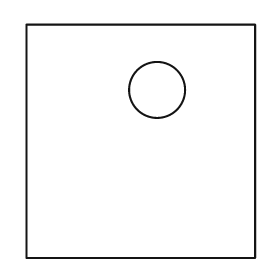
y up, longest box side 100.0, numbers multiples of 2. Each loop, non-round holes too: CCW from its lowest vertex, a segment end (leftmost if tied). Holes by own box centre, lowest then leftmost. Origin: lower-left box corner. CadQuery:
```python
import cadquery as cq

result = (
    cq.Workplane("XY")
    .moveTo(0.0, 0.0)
    .lineTo(98.0, 0.0)
    .lineTo(98.0, 100.0)
    .lineTo(0.0, 100.0)
    .close()
    .moveTo(56.0, 72.0)
    .circle(12.0)
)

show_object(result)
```